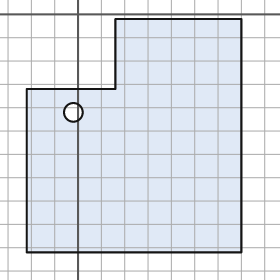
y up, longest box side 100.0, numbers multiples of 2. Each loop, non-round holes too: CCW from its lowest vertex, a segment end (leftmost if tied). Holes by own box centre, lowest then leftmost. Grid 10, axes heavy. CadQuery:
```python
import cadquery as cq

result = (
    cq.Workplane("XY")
    .moveTo(-22.0, -102.0)
    .lineTo(70.0, -102.0)
    .lineTo(70.0, -2.0)
    .lineTo(16.0, -2.0)
    .lineTo(16.0, -32.0)
    .lineTo(-22.0, -32.0)
    .close()
    .moveTo(-2.0, -42.0)
    .circle(4.0)
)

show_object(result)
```